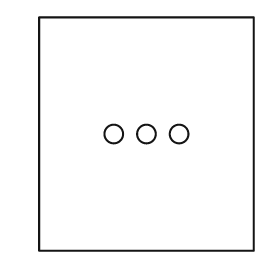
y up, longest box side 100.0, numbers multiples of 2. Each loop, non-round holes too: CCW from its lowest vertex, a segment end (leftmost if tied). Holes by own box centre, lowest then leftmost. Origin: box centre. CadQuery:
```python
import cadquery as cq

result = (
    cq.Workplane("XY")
    .moveTo(-46.0, -50.0)
    .lineTo(46.0, -50.0)
    .lineTo(46.0, 50.0)
    .lineTo(-46.0, 50.0)
    .close()
    .moveTo(-14.0, 0.0)
    .circle(4.0)
    .moveTo(0.0, 0.0)
    .circle(4.0)
    .moveTo(14.0, 0.0)
    .circle(4.0)
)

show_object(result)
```